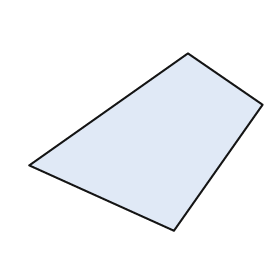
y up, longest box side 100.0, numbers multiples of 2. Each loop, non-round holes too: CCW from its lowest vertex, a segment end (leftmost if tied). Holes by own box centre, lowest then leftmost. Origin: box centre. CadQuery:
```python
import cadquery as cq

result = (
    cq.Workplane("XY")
    .moveTo(12.0, -38.0)
    .lineTo(50.0, 16.0)
    .lineTo(18.0, 38.0)
    .lineTo(-50.0, -10.0)
    .close()
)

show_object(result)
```